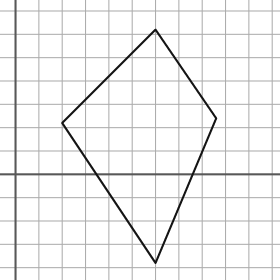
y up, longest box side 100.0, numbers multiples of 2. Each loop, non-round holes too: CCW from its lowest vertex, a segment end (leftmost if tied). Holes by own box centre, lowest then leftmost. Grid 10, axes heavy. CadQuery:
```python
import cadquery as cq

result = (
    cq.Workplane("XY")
    .moveTo(60.0, -38.0)
    .lineTo(86.0, 24.0)
    .lineTo(60.0, 62.0)
    .lineTo(20.0, 22.0)
    .close()
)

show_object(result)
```